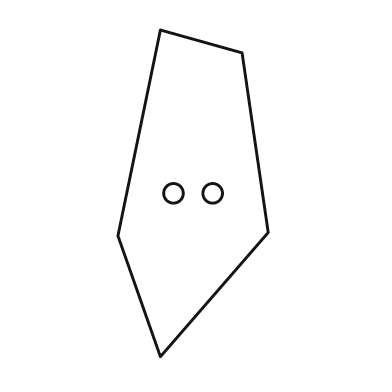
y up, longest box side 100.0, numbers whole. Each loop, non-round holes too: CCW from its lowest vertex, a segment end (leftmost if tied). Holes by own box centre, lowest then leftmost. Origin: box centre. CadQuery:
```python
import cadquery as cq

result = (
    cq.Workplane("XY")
    .moveTo(-10.0, -50.0)
    .lineTo(23.0, -12.0)
    .lineTo(15.0, 43.0)
    .lineTo(-10.0, 50.0)
    .lineTo(-23.0, -13.0)
    .close()
    .moveTo(-6.0, 0.0)
    .circle(3.0)
    .moveTo(6.0, 0.0)
    .circle(3.0)
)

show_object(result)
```